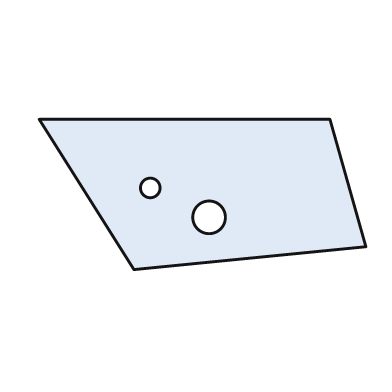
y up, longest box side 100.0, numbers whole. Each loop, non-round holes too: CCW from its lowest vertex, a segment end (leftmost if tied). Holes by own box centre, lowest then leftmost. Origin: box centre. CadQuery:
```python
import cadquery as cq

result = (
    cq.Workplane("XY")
    .moveTo(-21.0, -23.0)
    .lineTo(50.0, -16.0)
    .lineTo(39.0, 23.0)
    .lineTo(-50.0, 23.0)
    .close()
    .moveTo(2.0, -7.0)
    .circle(5.0)
    .moveTo(-16.0, 2.0)
    .circle(3.0)
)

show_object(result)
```